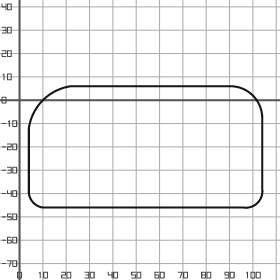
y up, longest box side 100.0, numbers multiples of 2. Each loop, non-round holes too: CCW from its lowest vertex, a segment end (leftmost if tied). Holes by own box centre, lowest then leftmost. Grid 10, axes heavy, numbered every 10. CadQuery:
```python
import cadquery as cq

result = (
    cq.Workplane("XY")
    .moveTo(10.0, -46.0)
    .lineTo(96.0, -46.0)
    .threePointArc((102.0, -44.0), (104.0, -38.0))
    .lineTo(104.0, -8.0)
    .threePointArc((100.0, 2.0), (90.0, 6.0))
    .lineTo(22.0, 6.0)
    .threePointArc((10.0, 0.0), (4.0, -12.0))
    .lineTo(4.0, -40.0)
    .threePointArc((6.0, -44.0), (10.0, -46.0))
    .close()
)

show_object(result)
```